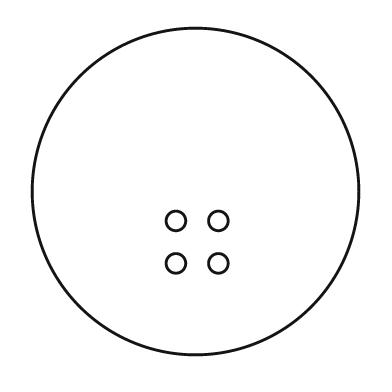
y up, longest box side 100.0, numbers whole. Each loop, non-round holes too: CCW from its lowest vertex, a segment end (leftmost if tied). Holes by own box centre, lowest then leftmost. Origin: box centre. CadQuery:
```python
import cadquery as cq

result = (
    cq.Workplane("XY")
    .moveTo(0.0, 0.0)
    .circle(50.0)
    .moveTo(-6.0, -22.0)
    .circle(3.0)
    .moveTo(7.0, -22.0)
    .circle(3.0)
    .moveTo(-6.0, -9.0)
    .circle(3.0)
    .moveTo(7.0, -9.0)
    .circle(3.0)
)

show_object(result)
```